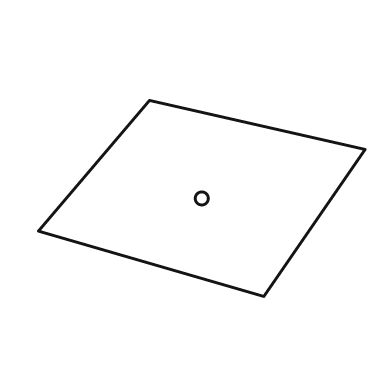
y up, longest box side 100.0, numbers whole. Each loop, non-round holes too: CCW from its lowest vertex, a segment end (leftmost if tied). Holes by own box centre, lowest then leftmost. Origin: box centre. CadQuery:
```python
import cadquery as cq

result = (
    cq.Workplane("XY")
    .moveTo(19.0, -30.0)
    .lineTo(50.0, 15.0)
    .lineTo(-16.0, 30.0)
    .lineTo(-50.0, -10.0)
    .close()
    .moveTo(0.0, 0.0)
    .circle(2.0)
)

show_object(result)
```